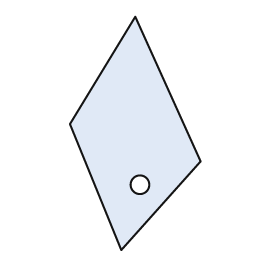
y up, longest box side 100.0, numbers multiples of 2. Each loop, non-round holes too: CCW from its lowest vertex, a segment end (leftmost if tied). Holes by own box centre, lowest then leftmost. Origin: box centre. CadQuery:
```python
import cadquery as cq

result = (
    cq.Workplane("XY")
    .moveTo(-6.0, -50.0)
    .lineTo(28.0, -12.0)
    .lineTo(0.0, 50.0)
    .lineTo(-28.0, 4.0)
    .close()
    .moveTo(2.0, -22.0)
    .circle(4.0)
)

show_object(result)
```